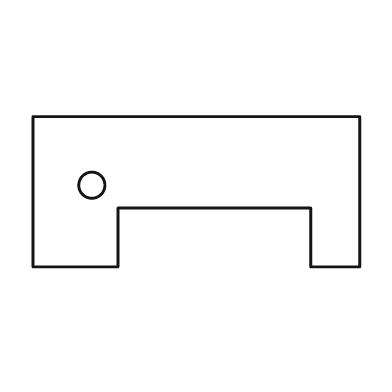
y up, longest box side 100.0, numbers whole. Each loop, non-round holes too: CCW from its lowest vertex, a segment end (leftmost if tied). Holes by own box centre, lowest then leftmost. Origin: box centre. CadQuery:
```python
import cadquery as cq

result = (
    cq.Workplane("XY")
    .moveTo(-50.0, -23.0)
    .lineTo(-24.0, -23.0)
    .lineTo(-24.0, -5.0)
    .lineTo(35.0, -5.0)
    .lineTo(35.0, -23.0)
    .lineTo(50.0, -23.0)
    .lineTo(50.0, 23.0)
    .lineTo(-50.0, 23.0)
    .close()
    .moveTo(-32.0, 2.0)
    .circle(4.0)
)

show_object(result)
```